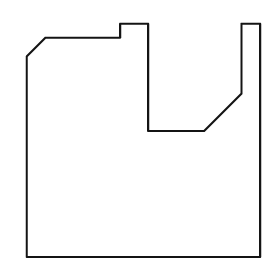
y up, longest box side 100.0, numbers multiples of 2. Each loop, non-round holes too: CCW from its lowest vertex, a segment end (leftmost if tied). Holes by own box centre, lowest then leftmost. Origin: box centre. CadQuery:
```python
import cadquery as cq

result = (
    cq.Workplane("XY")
    .moveTo(-50.0, -50.0)
    .lineTo(50.0, -50.0)
    .lineTo(50.0, 50.0)
    .lineTo(42.0, 50.0)
    .lineTo(42.0, 20.0)
    .lineTo(26.0, 4.0)
    .lineTo(2.0, 4.0)
    .lineTo(2.0, 50.0)
    .lineTo(-10.0, 50.0)
    .lineTo(-10.0, 44.0)
    .lineTo(-42.0, 44.0)
    .lineTo(-50.0, 36.0)
    .close()
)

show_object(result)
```